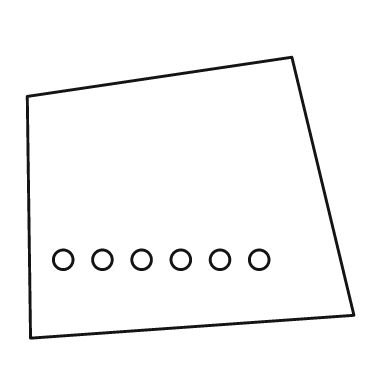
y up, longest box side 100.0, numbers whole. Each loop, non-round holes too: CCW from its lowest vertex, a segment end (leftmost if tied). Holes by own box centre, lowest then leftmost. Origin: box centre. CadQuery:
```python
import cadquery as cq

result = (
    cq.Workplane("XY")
    .moveTo(-49.0, -43.0)
    .lineTo(50.0, -36.0)
    .lineTo(31.0, 43.0)
    .lineTo(-50.0, 31.0)
    .close()
    .moveTo(-39.0, -19.0)
    .circle(3.0)
    .moveTo(-27.0, -19.0)
    .circle(3.0)
    .moveTo(-15.0, -19.0)
    .circle(3.0)
    .moveTo(-3.0, -19.0)
    .circle(3.0)
    .moveTo(9.0, -19.0)
    .circle(3.0)
    .moveTo(21.0, -19.0)
    .circle(3.0)
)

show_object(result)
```